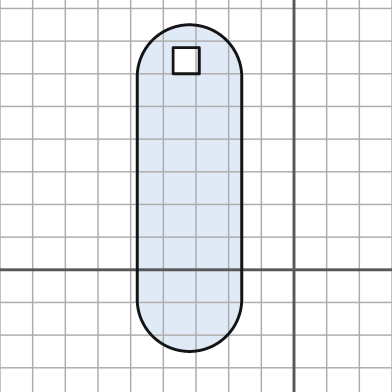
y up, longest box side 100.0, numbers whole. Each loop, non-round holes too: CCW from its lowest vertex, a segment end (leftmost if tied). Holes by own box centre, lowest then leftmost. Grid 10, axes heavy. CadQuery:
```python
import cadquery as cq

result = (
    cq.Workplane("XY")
    .moveTo(-48.0, -9.0)
    .threePointArc((-32.0, -25.0), (-16.0, -9.0))
    .lineTo(-16.0, 59.0)
    .threePointArc((-32.0, 75.0), (-48.0, 59.0))
    .close()
    .moveTo(-37.0, 60.0)
    .lineTo(-29.0, 60.0)
    .lineTo(-29.0, 68.0)
    .lineTo(-37.0, 68.0)
    .close()
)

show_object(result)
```